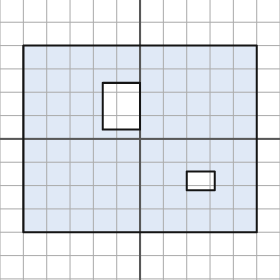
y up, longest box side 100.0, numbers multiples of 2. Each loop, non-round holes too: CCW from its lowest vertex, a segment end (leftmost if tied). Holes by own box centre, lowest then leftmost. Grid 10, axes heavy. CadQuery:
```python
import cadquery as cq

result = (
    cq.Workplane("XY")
    .moveTo(-50.0, -40.0)
    .lineTo(50.0, -40.0)
    .lineTo(50.0, 40.0)
    .lineTo(-50.0, 40.0)
    .close()
    .moveTo(20.0, -22.0)
    .lineTo(32.0, -22.0)
    .lineTo(32.0, -14.0)
    .lineTo(20.0, -14.0)
    .close()
    .moveTo(-16.0, 4.0)
    .lineTo(0.0, 4.0)
    .lineTo(0.0, 24.0)
    .lineTo(-16.0, 24.0)
    .close()
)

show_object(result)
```